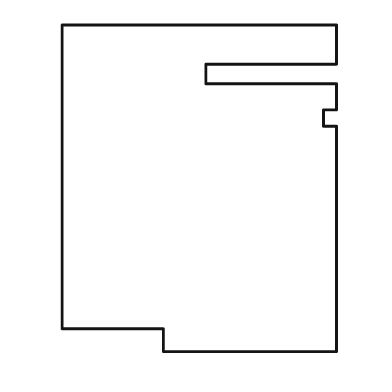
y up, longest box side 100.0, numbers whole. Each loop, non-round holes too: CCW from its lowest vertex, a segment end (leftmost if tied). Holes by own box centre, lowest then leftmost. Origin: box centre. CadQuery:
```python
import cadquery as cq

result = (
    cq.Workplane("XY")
    .moveTo(-11.0, -50.0)
    .lineTo(42.0, -50.0)
    .lineTo(42.0, 19.0)
    .lineTo(38.0, 19.0)
    .lineTo(38.0, 24.0)
    .lineTo(42.0, 24.0)
    .lineTo(42.0, 32.0)
    .lineTo(2.0, 32.0)
    .lineTo(2.0, 38.0)
    .lineTo(42.0, 38.0)
    .lineTo(42.0, 50.0)
    .lineTo(-42.0, 50.0)
    .lineTo(-42.0, -43.0)
    .lineTo(-11.0, -43.0)
    .close()
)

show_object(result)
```